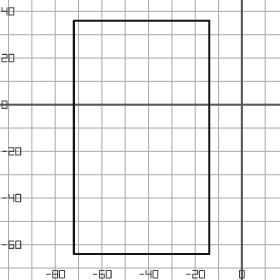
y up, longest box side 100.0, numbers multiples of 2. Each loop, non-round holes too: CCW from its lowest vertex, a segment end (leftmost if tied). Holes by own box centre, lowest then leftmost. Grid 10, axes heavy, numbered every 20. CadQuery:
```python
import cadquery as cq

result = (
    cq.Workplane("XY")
    .moveTo(-72.0, -64.0)
    .lineTo(-14.0, -64.0)
    .lineTo(-14.0, 36.0)
    .lineTo(-72.0, 36.0)
    .close()
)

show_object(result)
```